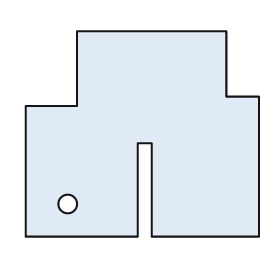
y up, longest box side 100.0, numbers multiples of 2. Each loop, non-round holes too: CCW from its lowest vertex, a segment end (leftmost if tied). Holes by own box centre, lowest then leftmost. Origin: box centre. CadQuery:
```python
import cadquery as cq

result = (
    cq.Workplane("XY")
    .moveTo(-50.0, -44.0)
    .lineTo(-2.0, -44.0)
    .lineTo(-2.0, -4.0)
    .lineTo(4.0, -4.0)
    .lineTo(4.0, -44.0)
    .lineTo(50.0, -44.0)
    .lineTo(50.0, 16.0)
    .lineTo(36.0, 16.0)
    .lineTo(36.0, 44.0)
    .lineTo(-28.0, 44.0)
    .lineTo(-28.0, 12.0)
    .lineTo(-50.0, 12.0)
    .close()
    .moveTo(-32.0, -30.0)
    .circle(4.0)
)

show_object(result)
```